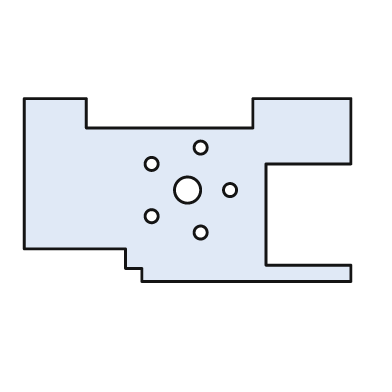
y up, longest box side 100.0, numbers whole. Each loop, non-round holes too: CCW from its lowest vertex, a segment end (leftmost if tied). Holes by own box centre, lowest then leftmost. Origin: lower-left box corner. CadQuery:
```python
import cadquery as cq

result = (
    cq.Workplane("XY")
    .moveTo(36.0, 0.0)
    .lineTo(100.0, 0.0)
    .lineTo(100.0, 5.0)
    .lineTo(74.0, 5.0)
    .lineTo(74.0, 36.0)
    .lineTo(100.0, 36.0)
    .lineTo(100.0, 56.0)
    .lineTo(70.0, 56.0)
    .lineTo(70.0, 47.0)
    .lineTo(19.0, 47.0)
    .lineTo(19.0, 56.0)
    .lineTo(0.0, 56.0)
    .lineTo(0.0, 10.0)
    .lineTo(31.0, 10.0)
    .lineTo(31.0, 4.0)
    .lineTo(36.0, 4.0)
    .close()
    .moveTo(54.0, 15.0)
    .circle(2.0)
    .moveTo(39.0, 20.0)
    .circle(2.0)
    .moveTo(50.0, 28.0)
    .circle(4.0)
    .moveTo(63.0, 28.0)
    .circle(2.0)
    .moveTo(39.0, 36.0)
    .circle(2.0)
    .moveTo(54.0, 41.0)
    .circle(2.0)
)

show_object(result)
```